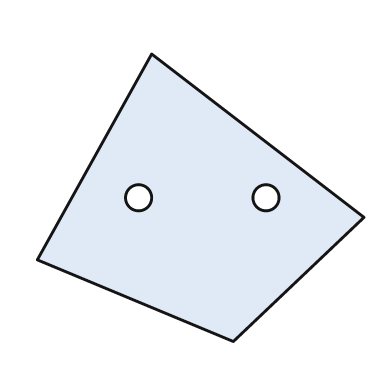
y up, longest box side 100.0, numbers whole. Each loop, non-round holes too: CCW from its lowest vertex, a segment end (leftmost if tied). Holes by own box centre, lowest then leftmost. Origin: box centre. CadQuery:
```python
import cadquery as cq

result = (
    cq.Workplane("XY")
    .moveTo(10.0, -44.0)
    .lineTo(50.0, -6.0)
    .lineTo(-15.0, 44.0)
    .lineTo(-50.0, -19.0)
    .close()
    .moveTo(-19.0, 0.0)
    .circle(4.0)
    .moveTo(20.0, 0.0)
    .circle(4.0)
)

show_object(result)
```